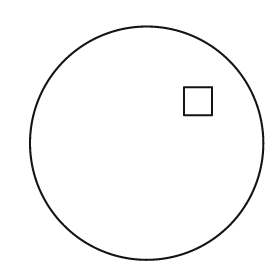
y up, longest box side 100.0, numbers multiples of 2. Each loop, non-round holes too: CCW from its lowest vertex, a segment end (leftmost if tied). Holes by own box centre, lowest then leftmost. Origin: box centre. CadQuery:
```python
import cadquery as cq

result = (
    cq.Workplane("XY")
    .moveTo(0.0, 0.0)
    .circle(50.0)
    .moveTo(16.0, 12.0)
    .lineTo(28.0, 12.0)
    .lineTo(28.0, 24.0)
    .lineTo(16.0, 24.0)
    .close()
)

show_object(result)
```